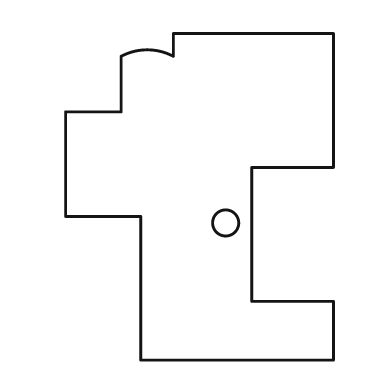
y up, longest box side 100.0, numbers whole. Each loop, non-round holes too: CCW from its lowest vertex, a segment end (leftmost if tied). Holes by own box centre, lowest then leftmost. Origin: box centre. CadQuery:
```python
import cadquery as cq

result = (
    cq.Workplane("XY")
    .moveTo(-18.0, -50.0)
    .lineTo(41.0, -50.0)
    .lineTo(41.0, -32.0)
    .lineTo(16.0, -32.0)
    .lineTo(16.0, 9.0)
    .lineTo(41.0, 9.0)
    .lineTo(41.0, 50.0)
    .lineTo(-8.0, 50.0)
    .lineTo(-8.0, 43.0)
    .threePointArc((-16.0, 45.0), (-24.0, 43.0))
    .lineTo(-24.0, 26.0)
    .lineTo(-41.0, 26.0)
    .lineTo(-41.0, -6.0)
    .lineTo(-18.0, -6.0)
    .close()
    .moveTo(8.0, -8.0)
    .circle(4.0)
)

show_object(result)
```